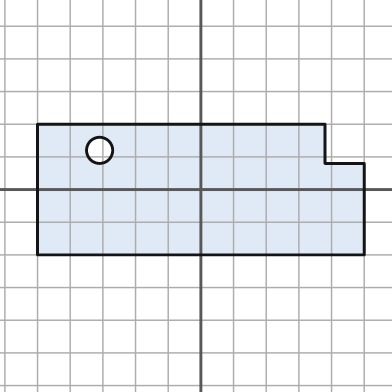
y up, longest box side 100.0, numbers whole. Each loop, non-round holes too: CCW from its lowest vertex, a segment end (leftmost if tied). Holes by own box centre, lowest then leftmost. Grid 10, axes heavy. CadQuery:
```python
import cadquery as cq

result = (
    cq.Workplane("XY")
    .moveTo(-50.0, -20.0)
    .lineTo(50.0, -20.0)
    .lineTo(50.0, 8.0)
    .lineTo(38.0, 8.0)
    .lineTo(38.0, 20.0)
    .lineTo(-50.0, 20.0)
    .close()
    .moveTo(-31.0, 12.0)
    .circle(4.0)
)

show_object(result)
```